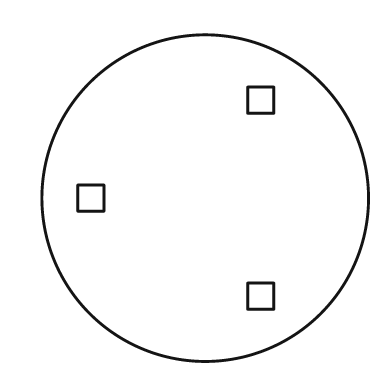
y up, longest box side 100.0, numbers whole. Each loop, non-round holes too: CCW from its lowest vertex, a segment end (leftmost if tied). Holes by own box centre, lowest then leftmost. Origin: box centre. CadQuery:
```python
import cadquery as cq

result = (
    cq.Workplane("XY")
    .moveTo(0.0, 0.0)
    .circle(50.0)
    .moveTo(13.0, -34.0)
    .lineTo(21.0, -34.0)
    .lineTo(21.0, -26.0)
    .lineTo(13.0, -26.0)
    .close()
    .moveTo(-39.0, -4.0)
    .lineTo(-31.0, -4.0)
    .lineTo(-31.0, 4.0)
    .lineTo(-39.0, 4.0)
    .close()
    .moveTo(13.0, 26.0)
    .lineTo(21.0, 26.0)
    .lineTo(21.0, 34.0)
    .lineTo(13.0, 34.0)
    .close()
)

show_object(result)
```